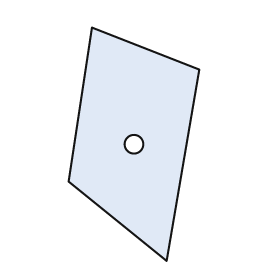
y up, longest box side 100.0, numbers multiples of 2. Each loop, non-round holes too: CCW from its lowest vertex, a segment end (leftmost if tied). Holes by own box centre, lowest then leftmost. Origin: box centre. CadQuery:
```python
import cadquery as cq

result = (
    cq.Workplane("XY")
    .moveTo(14.0, -50.0)
    .lineTo(28.0, 32.0)
    .lineTo(-18.0, 50.0)
    .lineTo(-28.0, -16.0)
    .close()
    .moveTo(0.0, 0.0)
    .circle(4.0)
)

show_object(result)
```